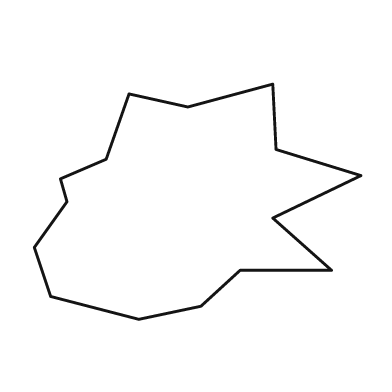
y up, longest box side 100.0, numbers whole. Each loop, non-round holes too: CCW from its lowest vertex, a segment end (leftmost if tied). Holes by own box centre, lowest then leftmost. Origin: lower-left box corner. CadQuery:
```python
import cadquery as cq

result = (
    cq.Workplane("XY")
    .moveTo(32.0, 0.0)
    .lineTo(51.0, 4.0)
    .lineTo(63.0, 15.0)
    .lineTo(91.0, 15.0)
    .lineTo(73.0, 31.0)
    .lineTo(100.0, 44.0)
    .lineTo(74.0, 52.0)
    .lineTo(73.0, 72.0)
    .lineTo(47.0, 65.0)
    .lineTo(29.0, 69.0)
    .lineTo(22.0, 49.0)
    .lineTo(8.0, 43.0)
    .lineTo(10.0, 36.0)
    .lineTo(0.0, 22.0)
    .lineTo(5.0, 7.0)
    .close()
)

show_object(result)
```